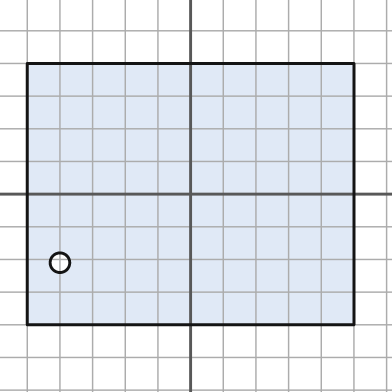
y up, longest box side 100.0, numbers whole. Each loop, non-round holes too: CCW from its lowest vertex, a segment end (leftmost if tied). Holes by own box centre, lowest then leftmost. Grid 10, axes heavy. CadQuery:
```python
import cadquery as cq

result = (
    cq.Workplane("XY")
    .moveTo(-50.0, -40.0)
    .lineTo(50.0, -40.0)
    .lineTo(50.0, 40.0)
    .lineTo(-50.0, 40.0)
    .close()
    .moveTo(-40.0, -21.0)
    .circle(3.0)
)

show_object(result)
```